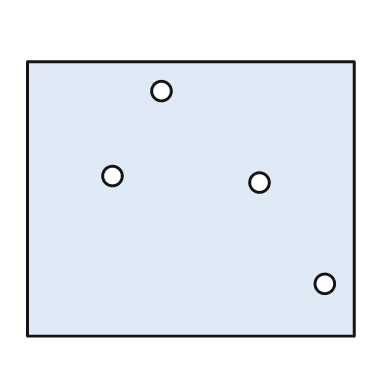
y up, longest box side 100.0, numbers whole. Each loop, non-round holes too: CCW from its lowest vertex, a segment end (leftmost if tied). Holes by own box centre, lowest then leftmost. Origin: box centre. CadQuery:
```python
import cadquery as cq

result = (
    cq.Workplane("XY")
    .moveTo(-50.0, -42.0)
    .lineTo(50.0, -42.0)
    .lineTo(50.0, 42.0)
    .lineTo(-50.0, 42.0)
    .close()
    .moveTo(41.0, -26.0)
    .circle(3.0)
    .moveTo(21.0, 5.0)
    .circle(3.0)
    .moveTo(-24.0, 7.0)
    .circle(3.0)
    .moveTo(-9.0, 33.0)
    .circle(3.0)
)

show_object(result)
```